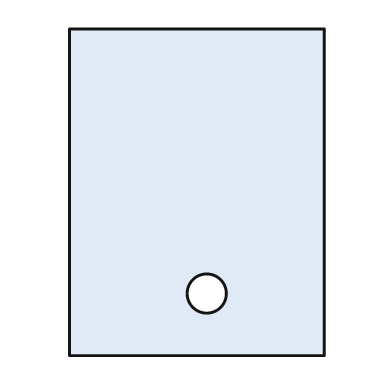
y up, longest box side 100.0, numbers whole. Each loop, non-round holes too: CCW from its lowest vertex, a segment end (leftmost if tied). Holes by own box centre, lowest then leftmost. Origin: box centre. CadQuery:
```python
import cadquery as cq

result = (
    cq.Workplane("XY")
    .moveTo(-39.0, -50.0)
    .lineTo(39.0, -50.0)
    .lineTo(39.0, 50.0)
    .lineTo(-39.0, 50.0)
    .close()
    .moveTo(3.0, -31.0)
    .circle(6.0)
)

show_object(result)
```